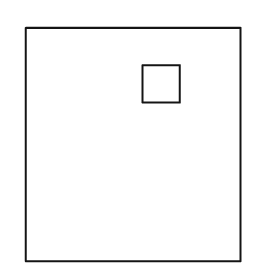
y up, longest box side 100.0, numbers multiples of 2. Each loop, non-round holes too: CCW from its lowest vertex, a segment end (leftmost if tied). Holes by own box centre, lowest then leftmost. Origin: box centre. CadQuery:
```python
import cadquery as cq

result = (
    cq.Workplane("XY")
    .moveTo(-46.0, -50.0)
    .lineTo(46.0, -50.0)
    .lineTo(46.0, 50.0)
    .lineTo(-46.0, 50.0)
    .close()
    .moveTo(4.0, 18.0)
    .lineTo(20.0, 18.0)
    .lineTo(20.0, 34.0)
    .lineTo(4.0, 34.0)
    .close()
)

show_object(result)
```